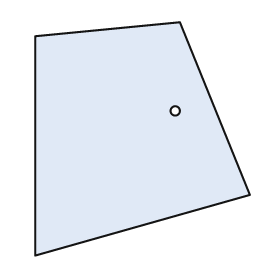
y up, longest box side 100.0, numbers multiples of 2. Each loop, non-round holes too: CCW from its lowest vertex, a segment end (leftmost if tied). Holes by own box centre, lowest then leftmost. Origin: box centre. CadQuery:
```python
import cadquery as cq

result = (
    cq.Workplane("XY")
    .moveTo(-46.0, -50.0)
    .lineTo(46.0, -24.0)
    .lineTo(16.0, 50.0)
    .lineTo(-46.0, 44.0)
    .close()
    .moveTo(14.0, 12.0)
    .circle(2.0)
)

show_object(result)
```